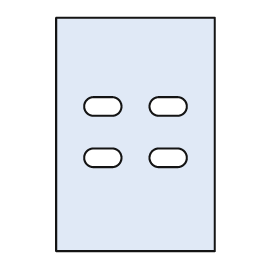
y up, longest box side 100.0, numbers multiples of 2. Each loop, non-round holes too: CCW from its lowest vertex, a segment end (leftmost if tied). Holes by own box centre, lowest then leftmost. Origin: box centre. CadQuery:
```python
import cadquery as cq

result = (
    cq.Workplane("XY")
    .moveTo(-34.0, -50.0)
    .lineTo(34.0, -50.0)
    .lineTo(34.0, 50.0)
    .lineTo(-34.0, 50.0)
    .close()
    .moveTo(-18.0, -14.0)
    .lineTo(-10.0, -14.0)
    .threePointArc((-6.0, -10.0), (-10.0, -6.0))
    .lineTo(-18.0, -6.0)
    .threePointArc((-22.0, -10.0), (-18.0, -14.0))
    .close()
    .moveTo(10.0, -14.0)
    .lineTo(18.0, -14.0)
    .threePointArc((22.0, -10.0), (18.0, -6.0))
    .lineTo(10.0, -6.0)
    .threePointArc((6.0, -10.0), (10.0, -14.0))
    .close()
    .moveTo(-18.0, 8.0)
    .lineTo(-10.0, 8.0)
    .threePointArc((-6.0, 12.0), (-10.0, 16.0))
    .lineTo(-18.0, 16.0)
    .threePointArc((-22.0, 12.0), (-18.0, 8.0))
    .close()
    .moveTo(10.0, 8.0)
    .lineTo(18.0, 8.0)
    .threePointArc((22.0, 12.0), (18.0, 16.0))
    .lineTo(10.0, 16.0)
    .threePointArc((6.0, 12.0), (10.0, 8.0))
    .close()
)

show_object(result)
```